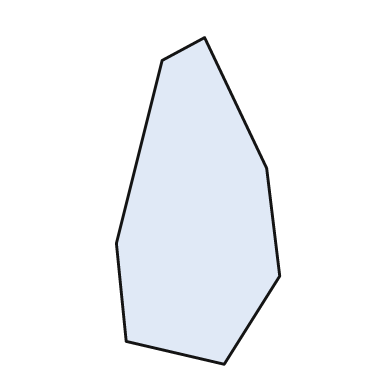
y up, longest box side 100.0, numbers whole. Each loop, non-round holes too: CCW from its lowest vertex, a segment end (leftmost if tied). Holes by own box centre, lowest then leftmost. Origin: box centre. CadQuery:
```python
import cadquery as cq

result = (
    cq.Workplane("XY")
    .moveTo(8.0, -50.0)
    .lineTo(25.0, -23.0)
    .lineTo(21.0, 10.0)
    .lineTo(2.0, 50.0)
    .lineTo(-11.0, 43.0)
    .lineTo(-25.0, -13.0)
    .lineTo(-22.0, -43.0)
    .close()
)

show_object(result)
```